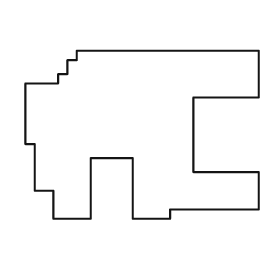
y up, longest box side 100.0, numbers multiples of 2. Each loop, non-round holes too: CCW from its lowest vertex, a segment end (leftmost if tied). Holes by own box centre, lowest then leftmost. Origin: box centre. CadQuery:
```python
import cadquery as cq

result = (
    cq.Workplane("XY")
    .moveTo(-38.0, -36.0)
    .lineTo(-22.0, -36.0)
    .lineTo(-22.0, -10.0)
    .lineTo(-4.0, -10.0)
    .lineTo(-4.0, -36.0)
    .lineTo(12.0, -36.0)
    .lineTo(12.0, -32.0)
    .lineTo(50.0, -32.0)
    .lineTo(50.0, -16.0)
    .lineTo(22.0, -16.0)
    .lineTo(22.0, 16.0)
    .lineTo(50.0, 16.0)
    .lineTo(50.0, 36.0)
    .lineTo(-28.0, 36.0)
    .lineTo(-28.0, 32.0)
    .lineTo(-32.0, 32.0)
    .lineTo(-32.0, 26.0)
    .lineTo(-36.0, 26.0)
    .lineTo(-36.0, 22.0)
    .lineTo(-50.0, 22.0)
    .lineTo(-50.0, -4.0)
    .lineTo(-46.0, -4.0)
    .lineTo(-46.0, -24.0)
    .lineTo(-38.0, -24.0)
    .close()
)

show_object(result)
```